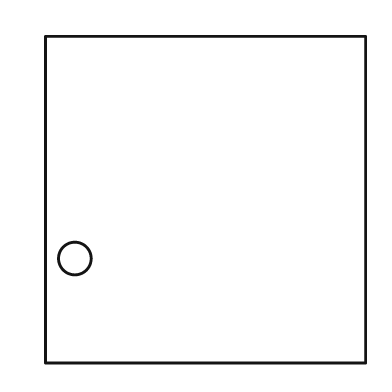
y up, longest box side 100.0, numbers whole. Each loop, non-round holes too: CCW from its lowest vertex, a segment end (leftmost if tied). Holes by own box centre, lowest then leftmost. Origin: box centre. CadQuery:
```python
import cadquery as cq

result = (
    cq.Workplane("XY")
    .moveTo(-49.0, -50.0)
    .lineTo(49.0, -50.0)
    .lineTo(49.0, 50.0)
    .lineTo(-49.0, 50.0)
    .close()
    .moveTo(-40.0, -18.0)
    .circle(5.0)
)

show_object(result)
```